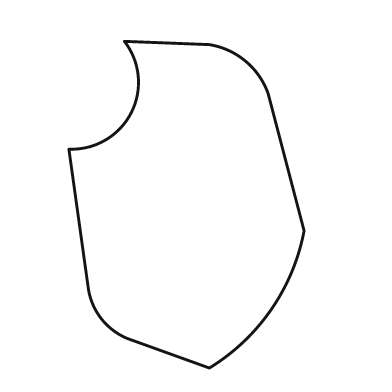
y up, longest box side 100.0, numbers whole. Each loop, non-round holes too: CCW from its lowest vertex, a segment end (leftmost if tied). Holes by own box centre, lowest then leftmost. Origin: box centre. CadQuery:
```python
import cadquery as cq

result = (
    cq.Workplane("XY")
    .moveTo(7.0, -50.0)
    .threePointArc((26.0, -32.0), (36.0, -8.0))
    .lineTo(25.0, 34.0)
    .threePointArc((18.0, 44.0), (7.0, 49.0))
    .lineTo(-19.0, 50.0)
    .threePointArc((-17.0, 28.0), (-36.0, 17.0))
    .lineTo(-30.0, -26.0)
    .threePointArc((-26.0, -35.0), (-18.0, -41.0))
    .close()
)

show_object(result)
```